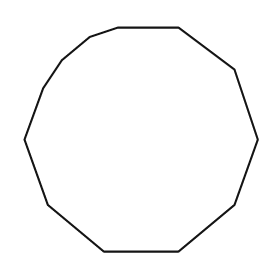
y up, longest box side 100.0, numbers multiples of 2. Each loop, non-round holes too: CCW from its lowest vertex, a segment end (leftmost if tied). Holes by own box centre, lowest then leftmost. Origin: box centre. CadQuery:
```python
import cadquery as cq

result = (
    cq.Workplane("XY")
    .moveTo(-16.0, -48.0)
    .lineTo(16.0, -48.0)
    .lineTo(40.0, -28.0)
    .lineTo(50.0, 0.0)
    .lineTo(40.0, 30.0)
    .lineTo(16.0, 48.0)
    .lineTo(-10.0, 48.0)
    .lineTo(-22.0, 44.0)
    .lineTo(-34.0, 34.0)
    .lineTo(-42.0, 22.0)
    .lineTo(-50.0, 0.0)
    .lineTo(-40.0, -28.0)
    .close()
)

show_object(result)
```